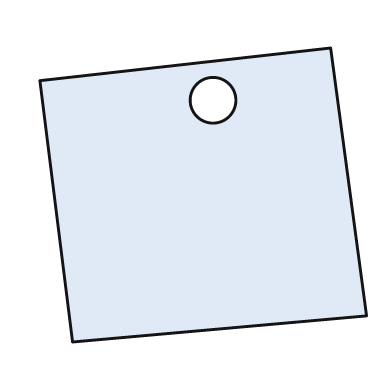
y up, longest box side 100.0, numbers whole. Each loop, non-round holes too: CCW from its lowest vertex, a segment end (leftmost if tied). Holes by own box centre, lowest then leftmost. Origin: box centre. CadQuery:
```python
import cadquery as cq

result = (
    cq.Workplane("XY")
    .moveTo(-40.0, -45.0)
    .lineTo(50.0, -37.0)
    .lineTo(39.0, 45.0)
    .lineTo(-50.0, 35.0)
    .close()
    .moveTo(3.0, 29.0)
    .circle(7.0)
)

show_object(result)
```